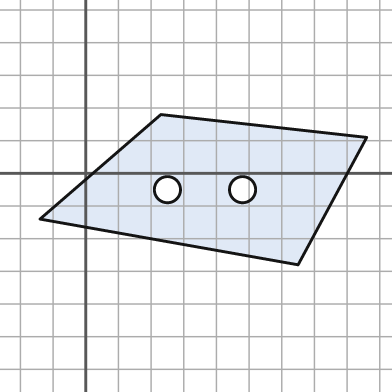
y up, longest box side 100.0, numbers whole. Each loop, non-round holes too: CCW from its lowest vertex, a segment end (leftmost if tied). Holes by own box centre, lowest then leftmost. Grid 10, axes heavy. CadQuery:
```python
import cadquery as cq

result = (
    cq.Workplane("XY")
    .moveTo(65.0, -28.0)
    .lineTo(86.0, 11.0)
    .lineTo(23.0, 18.0)
    .lineTo(-14.0, -14.0)
    .close()
    .moveTo(25.0, -5.0)
    .circle(4.0)
    .moveTo(48.0, -5.0)
    .circle(4.0)
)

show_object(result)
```